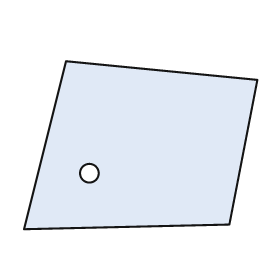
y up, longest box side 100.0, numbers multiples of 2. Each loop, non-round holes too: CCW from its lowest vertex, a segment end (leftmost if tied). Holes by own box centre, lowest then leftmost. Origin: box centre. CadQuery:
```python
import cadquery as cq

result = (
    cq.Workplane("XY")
    .moveTo(-50.0, -36.0)
    .lineTo(38.0, -34.0)
    .lineTo(50.0, 28.0)
    .lineTo(-32.0, 36.0)
    .close()
    .moveTo(-22.0, -12.0)
    .circle(4.0)
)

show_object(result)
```